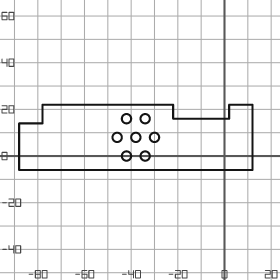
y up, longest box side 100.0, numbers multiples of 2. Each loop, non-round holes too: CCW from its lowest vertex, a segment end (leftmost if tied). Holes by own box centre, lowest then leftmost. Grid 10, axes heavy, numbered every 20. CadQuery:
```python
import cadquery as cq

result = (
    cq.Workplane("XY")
    .moveTo(-88.0, -6.0)
    .lineTo(12.0, -6.0)
    .lineTo(12.0, 22.0)
    .lineTo(2.0, 22.0)
    .lineTo(2.0, 16.0)
    .lineTo(-22.0, 16.0)
    .lineTo(-22.0, 22.0)
    .lineTo(-78.0, 22.0)
    .lineTo(-78.0, 14.0)
    .lineTo(-88.0, 14.0)
    .close()
    .moveTo(-42.0, 0.0)
    .circle(2.0)
    .moveTo(-34.0, 0.0)
    .circle(2.0)
    .moveTo(-46.0, 8.0)
    .circle(2.0)
    .moveTo(-38.0, 8.0)
    .circle(2.0)
    .moveTo(-30.0, 8.0)
    .circle(2.0)
    .moveTo(-42.0, 16.0)
    .circle(2.0)
    .moveTo(-34.0, 16.0)
    .circle(2.0)
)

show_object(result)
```